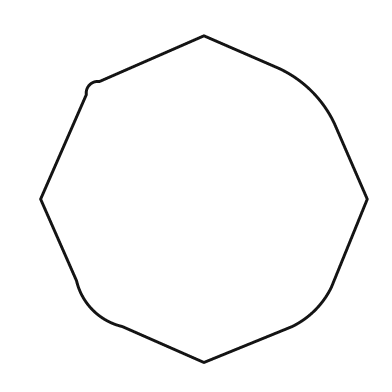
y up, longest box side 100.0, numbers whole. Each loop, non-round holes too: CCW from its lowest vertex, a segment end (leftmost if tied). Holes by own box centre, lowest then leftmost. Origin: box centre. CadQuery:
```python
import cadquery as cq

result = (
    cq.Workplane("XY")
    .moveTo(0.0, -50.0)
    .lineTo(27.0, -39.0)
    .threePointArc((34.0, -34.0), (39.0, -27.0))
    .lineTo(50.0, 0.0)
    .lineTo(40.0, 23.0)
    .threePointArc((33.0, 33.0), (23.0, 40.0))
    .lineTo(0.0, 50.0)
    .lineTo(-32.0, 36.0)
    .threePointArc((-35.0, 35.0), (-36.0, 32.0))
    .lineTo(-50.0, 0.0)
    .lineTo(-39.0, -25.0)
    .threePointArc((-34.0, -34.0), (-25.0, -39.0))
    .close()
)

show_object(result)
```